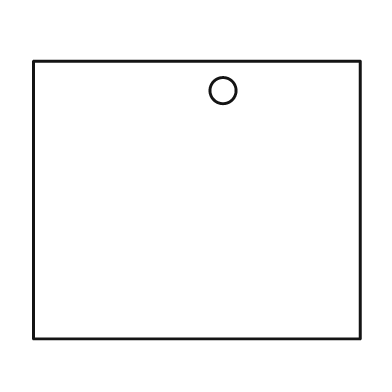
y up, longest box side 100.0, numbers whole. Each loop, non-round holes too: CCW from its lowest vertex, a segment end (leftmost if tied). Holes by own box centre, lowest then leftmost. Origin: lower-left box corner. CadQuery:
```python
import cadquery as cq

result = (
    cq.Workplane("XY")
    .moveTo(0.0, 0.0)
    .lineTo(100.0, 0.0)
    .lineTo(100.0, 85.0)
    .lineTo(0.0, 85.0)
    .close()
    .moveTo(58.0, 76.0)
    .circle(4.0)
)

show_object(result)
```